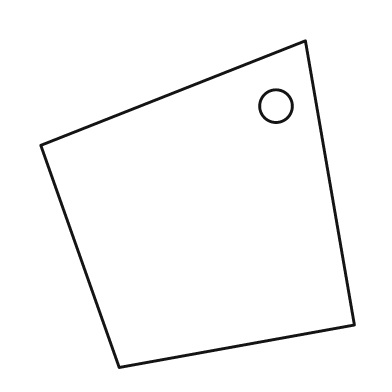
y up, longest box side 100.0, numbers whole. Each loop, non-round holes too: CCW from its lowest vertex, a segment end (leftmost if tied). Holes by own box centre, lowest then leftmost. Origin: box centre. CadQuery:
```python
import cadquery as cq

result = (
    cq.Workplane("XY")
    .moveTo(-24.0, -50.0)
    .lineTo(48.0, -37.0)
    .lineTo(33.0, 50.0)
    .lineTo(-48.0, 18.0)
    .close()
    .moveTo(24.0, 30.0)
    .circle(5.0)
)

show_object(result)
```